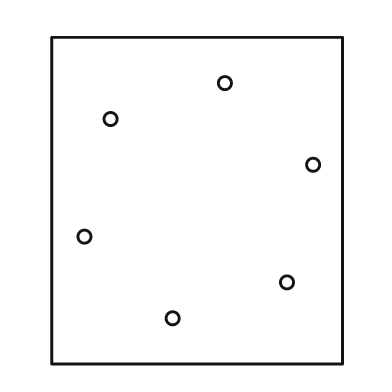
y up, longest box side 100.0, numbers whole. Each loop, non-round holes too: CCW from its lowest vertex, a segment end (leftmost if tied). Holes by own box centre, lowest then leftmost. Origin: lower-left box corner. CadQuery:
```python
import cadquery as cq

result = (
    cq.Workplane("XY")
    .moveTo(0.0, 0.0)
    .lineTo(89.0, 0.0)
    .lineTo(89.0, 100.0)
    .lineTo(0.0, 100.0)
    .close()
    .moveTo(37.0, 14.0)
    .circle(2.0)
    .moveTo(72.0, 25.0)
    .circle(2.0)
    .moveTo(10.0, 39.0)
    .circle(2.0)
    .moveTo(80.0, 61.0)
    .circle(2.0)
    .moveTo(18.0, 75.0)
    .circle(2.0)
    .moveTo(53.0, 86.0)
    .circle(2.0)
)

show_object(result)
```